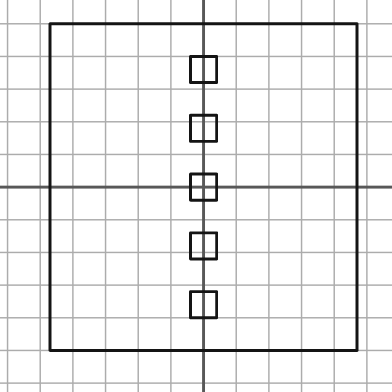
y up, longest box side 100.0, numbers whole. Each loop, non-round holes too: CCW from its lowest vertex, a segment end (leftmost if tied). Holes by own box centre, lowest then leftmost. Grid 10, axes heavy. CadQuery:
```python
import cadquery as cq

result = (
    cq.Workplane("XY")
    .moveTo(-47.0, -50.0)
    .lineTo(47.0, -50.0)
    .lineTo(47.0, 50.0)
    .lineTo(-47.0, 50.0)
    .close()
    .moveTo(-4.0, -40.0)
    .lineTo(4.0, -40.0)
    .lineTo(4.0, -32.0)
    .lineTo(-4.0, -32.0)
    .close()
    .moveTo(-4.0, -22.0)
    .lineTo(4.0, -22.0)
    .lineTo(4.0, -14.0)
    .lineTo(-4.0, -14.0)
    .close()
    .moveTo(-4.0, -4.0)
    .lineTo(4.0, -4.0)
    .lineTo(4.0, 4.0)
    .lineTo(-4.0, 4.0)
    .close()
    .moveTo(-4.0, 14.0)
    .lineTo(4.0, 14.0)
    .lineTo(4.0, 22.0)
    .lineTo(-4.0, 22.0)
    .close()
    .moveTo(-4.0, 32.0)
    .lineTo(4.0, 32.0)
    .lineTo(4.0, 40.0)
    .lineTo(-4.0, 40.0)
    .close()
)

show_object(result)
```